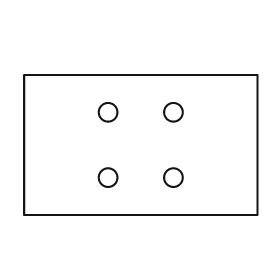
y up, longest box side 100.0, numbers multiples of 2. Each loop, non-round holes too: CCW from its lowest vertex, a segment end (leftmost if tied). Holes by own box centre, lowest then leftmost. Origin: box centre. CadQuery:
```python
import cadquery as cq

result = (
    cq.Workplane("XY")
    .moveTo(-50.0, -30.0)
    .lineTo(50.0, -30.0)
    .lineTo(50.0, 30.0)
    .lineTo(-50.0, 30.0)
    .close()
    .moveTo(-14.0, -14.0)
    .circle(4.0)
    .moveTo(14.0, -14.0)
    .circle(4.0)
    .moveTo(-14.0, 14.0)
    .circle(4.0)
    .moveTo(14.0, 14.0)
    .circle(4.0)
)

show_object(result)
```